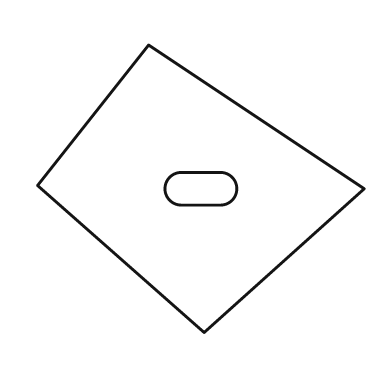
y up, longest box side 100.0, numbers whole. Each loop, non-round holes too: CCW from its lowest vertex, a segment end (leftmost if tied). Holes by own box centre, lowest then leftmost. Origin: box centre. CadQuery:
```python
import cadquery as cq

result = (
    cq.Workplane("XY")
    .moveTo(1.0, -44.0)
    .lineTo(50.0, 0.0)
    .lineTo(-16.0, 44.0)
    .lineTo(-50.0, 1.0)
    .close()
    .moveTo(-6.0, -5.0)
    .lineTo(6.0, -5.0)
    .threePointArc((11.0, 0.0), (6.0, 5.0))
    .lineTo(-6.0, 5.0)
    .threePointArc((-11.0, 0.0), (-6.0, -5.0))
    .close()
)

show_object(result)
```